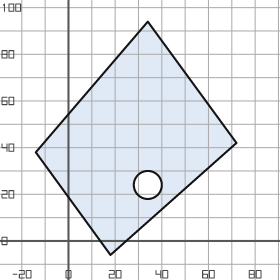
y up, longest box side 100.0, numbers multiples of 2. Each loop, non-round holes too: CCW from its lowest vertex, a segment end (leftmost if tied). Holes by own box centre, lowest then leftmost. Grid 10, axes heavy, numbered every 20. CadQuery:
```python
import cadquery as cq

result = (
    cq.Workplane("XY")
    .moveTo(18.0, -6.0)
    .lineTo(72.0, 42.0)
    .lineTo(34.0, 94.0)
    .lineTo(-14.0, 38.0)
    .close()
    .moveTo(34.0, 24.0)
    .circle(6.0)
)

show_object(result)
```